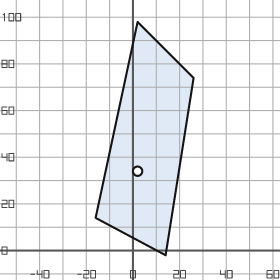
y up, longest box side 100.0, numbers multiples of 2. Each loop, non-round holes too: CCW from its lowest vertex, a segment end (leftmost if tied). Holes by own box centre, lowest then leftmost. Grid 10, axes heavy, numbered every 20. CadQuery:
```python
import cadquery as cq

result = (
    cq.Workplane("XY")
    .moveTo(14.0, -2.0)
    .lineTo(26.0, 74.0)
    .lineTo(2.0, 98.0)
    .lineTo(-16.0, 14.0)
    .close()
    .moveTo(2.0, 34.0)
    .circle(2.0)
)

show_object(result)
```